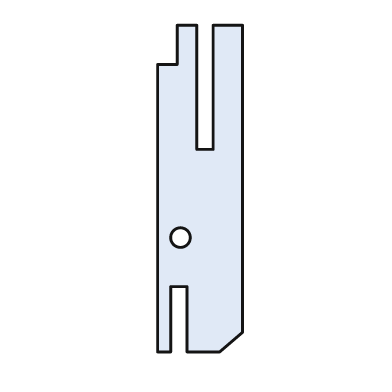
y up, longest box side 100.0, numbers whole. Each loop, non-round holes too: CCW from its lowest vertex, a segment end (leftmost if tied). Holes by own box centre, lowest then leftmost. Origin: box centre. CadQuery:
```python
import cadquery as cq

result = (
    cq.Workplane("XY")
    .moveTo(-13.0, -50.0)
    .lineTo(-9.0, -50.0)
    .lineTo(-9.0, -30.0)
    .lineTo(-4.0, -30.0)
    .lineTo(-4.0, -50.0)
    .lineTo(6.0, -50.0)
    .lineTo(13.0, -44.0)
    .lineTo(13.0, 50.0)
    .lineTo(4.0, 50.0)
    .lineTo(4.0, 12.0)
    .lineTo(-1.0, 12.0)
    .lineTo(-1.0, 50.0)
    .lineTo(-7.0, 50.0)
    .lineTo(-7.0, 38.0)
    .lineTo(-13.0, 38.0)
    .close()
    .moveTo(-6.0, -15.0)
    .circle(3.0)
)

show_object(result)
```